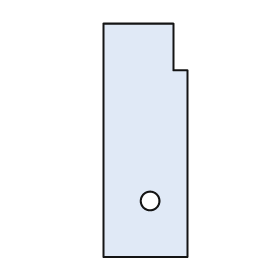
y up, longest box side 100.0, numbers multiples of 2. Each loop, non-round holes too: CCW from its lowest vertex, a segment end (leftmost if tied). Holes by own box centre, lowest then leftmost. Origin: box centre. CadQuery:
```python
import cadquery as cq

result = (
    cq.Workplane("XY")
    .moveTo(-18.0, -50.0)
    .lineTo(18.0, -50.0)
    .lineTo(18.0, 30.0)
    .lineTo(12.0, 30.0)
    .lineTo(12.0, 50.0)
    .lineTo(-18.0, 50.0)
    .close()
    .moveTo(2.0, -26.0)
    .circle(4.0)
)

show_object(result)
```